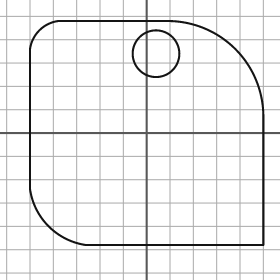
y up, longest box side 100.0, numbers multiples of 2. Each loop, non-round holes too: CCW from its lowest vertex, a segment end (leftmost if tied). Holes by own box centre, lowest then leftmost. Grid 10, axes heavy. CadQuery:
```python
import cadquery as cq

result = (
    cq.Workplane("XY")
    .moveTo(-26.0, -48.0)
    .lineTo(50.0, -48.0)
    .lineTo(50.0, 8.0)
    .threePointArc((38.0, 36.0), (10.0, 48.0))
    .lineTo(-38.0, 48.0)
    .threePointArc((-46.0, 44.0), (-50.0, 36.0))
    .lineTo(-50.0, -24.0)
    .threePointArc((-42.0, -40.0), (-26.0, -48.0))
    .close()
    .moveTo(4.0, 34.0)
    .circle(10.0)
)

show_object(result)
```